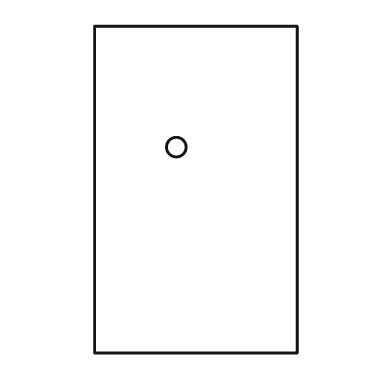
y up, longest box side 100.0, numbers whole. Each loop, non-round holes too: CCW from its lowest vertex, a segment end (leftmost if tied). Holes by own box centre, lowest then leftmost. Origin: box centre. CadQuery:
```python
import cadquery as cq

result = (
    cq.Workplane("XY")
    .moveTo(-31.0, -50.0)
    .lineTo(31.0, -50.0)
    .lineTo(31.0, 50.0)
    .lineTo(-31.0, 50.0)
    .close()
    .moveTo(-6.0, 13.0)
    .circle(3.0)
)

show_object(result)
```